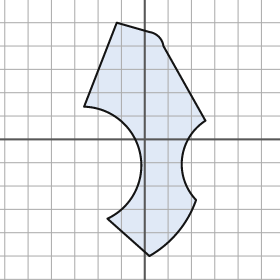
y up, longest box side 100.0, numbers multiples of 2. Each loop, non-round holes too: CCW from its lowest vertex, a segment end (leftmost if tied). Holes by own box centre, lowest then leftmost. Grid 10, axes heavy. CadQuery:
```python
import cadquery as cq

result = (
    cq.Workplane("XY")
    .moveTo(2.0, -50.0)
    .threePointArc((14.0, -40.0), (22.0, -26.0))
    .threePointArc((16.0, -8.0), (26.0, 8.0))
    .lineTo(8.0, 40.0)
    .threePointArc((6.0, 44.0), (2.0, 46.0))
    .lineTo(-12.0, 50.0)
    .lineTo(-26.0, 14.0)
    .threePointArc((-2.0, -6.0), (-16.0, -34.0))
    .close()
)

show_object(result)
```